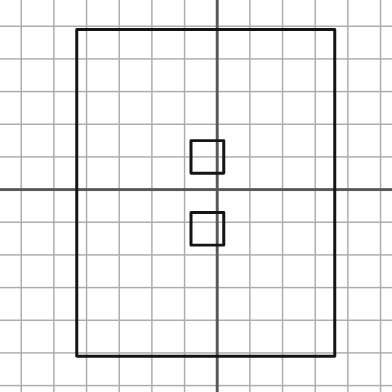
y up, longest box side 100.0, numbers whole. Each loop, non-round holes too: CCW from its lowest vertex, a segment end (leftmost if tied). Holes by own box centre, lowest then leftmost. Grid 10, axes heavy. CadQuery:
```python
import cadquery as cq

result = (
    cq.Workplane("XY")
    .moveTo(-43.0, -51.0)
    .lineTo(36.0, -51.0)
    .lineTo(36.0, 49.0)
    .lineTo(-43.0, 49.0)
    .close()
    .moveTo(-8.0, -17.0)
    .lineTo(2.0, -17.0)
    .lineTo(2.0, -7.0)
    .lineTo(-8.0, -7.0)
    .close()
    .moveTo(-8.0, 5.0)
    .lineTo(2.0, 5.0)
    .lineTo(2.0, 15.0)
    .lineTo(-8.0, 15.0)
    .close()
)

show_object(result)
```